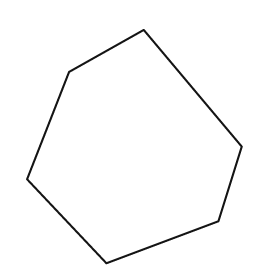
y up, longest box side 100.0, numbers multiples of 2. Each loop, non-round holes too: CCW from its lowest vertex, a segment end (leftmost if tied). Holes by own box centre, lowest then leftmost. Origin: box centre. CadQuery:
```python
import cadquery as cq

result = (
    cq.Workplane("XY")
    .moveTo(-12.0, -50.0)
    .lineTo(36.0, -32.0)
    .lineTo(46.0, 0.0)
    .lineTo(4.0, 50.0)
    .lineTo(-28.0, 32.0)
    .lineTo(-46.0, -14.0)
    .close()
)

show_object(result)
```